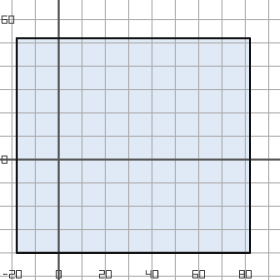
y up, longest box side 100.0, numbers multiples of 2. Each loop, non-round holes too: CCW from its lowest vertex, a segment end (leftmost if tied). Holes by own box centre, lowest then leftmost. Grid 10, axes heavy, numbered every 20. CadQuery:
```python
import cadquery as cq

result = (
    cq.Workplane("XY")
    .moveTo(-18.0, -40.0)
    .lineTo(82.0, -40.0)
    .lineTo(82.0, 52.0)
    .lineTo(-18.0, 52.0)
    .close()
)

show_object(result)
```